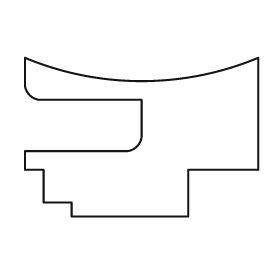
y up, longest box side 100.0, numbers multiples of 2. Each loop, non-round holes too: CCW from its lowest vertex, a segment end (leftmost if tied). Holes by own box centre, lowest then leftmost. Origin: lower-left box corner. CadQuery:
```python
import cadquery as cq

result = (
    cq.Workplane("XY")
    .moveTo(20.0, 0.0)
    .lineTo(70.0, 0.0)
    .lineTo(70.0, 20.0)
    .lineTo(100.0, 20.0)
    .lineTo(100.0, 68.0)
    .threePointArc((50.0, 58.0), (0.0, 68.0))
    .lineTo(0.0, 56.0)
    .threePointArc((2.0, 52.0), (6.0, 50.0))
    .lineTo(50.0, 50.0)
    .lineTo(50.0, 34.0)
    .threePointArc((48.0, 30.0), (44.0, 28.0))
    .lineTo(0.0, 28.0)
    .lineTo(0.0, 20.0)
    .lineTo(8.0, 20.0)
    .lineTo(8.0, 6.0)
    .lineTo(20.0, 6.0)
    .close()
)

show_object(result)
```